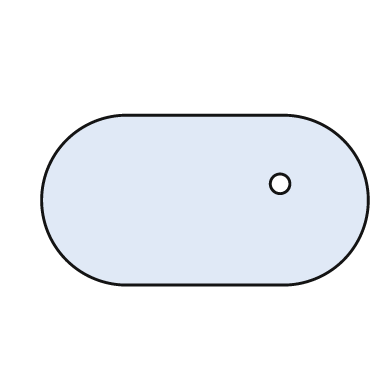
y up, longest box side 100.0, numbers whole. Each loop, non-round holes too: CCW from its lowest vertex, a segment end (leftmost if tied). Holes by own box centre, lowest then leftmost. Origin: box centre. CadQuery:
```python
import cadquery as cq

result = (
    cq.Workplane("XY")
    .moveTo(-24.0, -26.0)
    .lineTo(24.0, -26.0)
    .threePointArc((50.0, 0.0), (24.0, 26.0))
    .lineTo(-24.0, 26.0)
    .threePointArc((-50.0, 0.0), (-24.0, -26.0))
    .close()
    .moveTo(23.0, 5.0)
    .circle(3.0)
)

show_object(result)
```